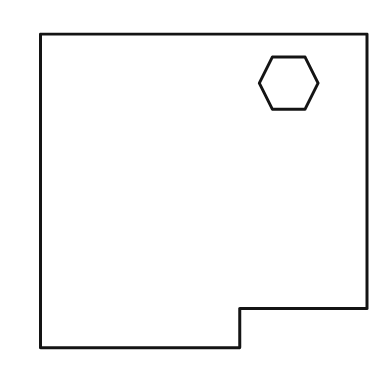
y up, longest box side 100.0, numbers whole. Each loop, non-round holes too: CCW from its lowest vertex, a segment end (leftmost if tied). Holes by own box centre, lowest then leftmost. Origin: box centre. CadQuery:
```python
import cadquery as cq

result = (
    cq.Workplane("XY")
    .moveTo(-50.0, -48.0)
    .lineTo(11.0, -48.0)
    .lineTo(11.0, -36.0)
    .lineTo(50.0, -36.0)
    .lineTo(50.0, 48.0)
    .lineTo(-50.0, 48.0)
    .close()
    .moveTo(21.0, 25.0)
    .lineTo(31.0, 25.0)
    .lineTo(35.0, 33.0)
    .lineTo(31.0, 41.0)
    .lineTo(21.0, 41.0)
    .lineTo(17.0, 33.0)
    .close()
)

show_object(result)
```